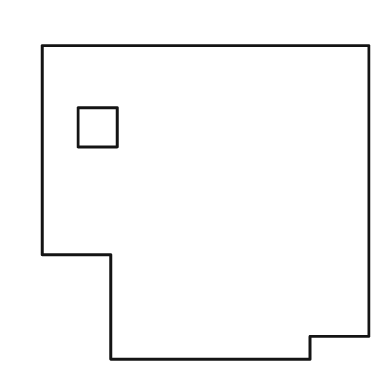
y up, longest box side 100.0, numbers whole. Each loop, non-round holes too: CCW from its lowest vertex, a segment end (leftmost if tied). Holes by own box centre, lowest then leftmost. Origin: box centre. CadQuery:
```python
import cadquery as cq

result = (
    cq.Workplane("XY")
    .moveTo(-29.0, -48.0)
    .lineTo(32.0, -48.0)
    .lineTo(32.0, -41.0)
    .lineTo(50.0, -41.0)
    .lineTo(50.0, 48.0)
    .lineTo(-50.0, 48.0)
    .lineTo(-50.0, -16.0)
    .lineTo(-29.0, -16.0)
    .close()
    .moveTo(-39.0, 17.0)
    .lineTo(-27.0, 17.0)
    .lineTo(-27.0, 29.0)
    .lineTo(-39.0, 29.0)
    .close()
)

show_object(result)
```